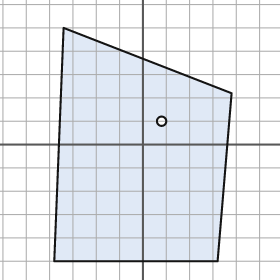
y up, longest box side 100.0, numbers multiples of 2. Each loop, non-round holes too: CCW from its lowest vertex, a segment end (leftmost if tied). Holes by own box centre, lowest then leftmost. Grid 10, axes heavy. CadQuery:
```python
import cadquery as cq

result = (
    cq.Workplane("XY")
    .moveTo(-38.0, -50.0)
    .lineTo(32.0, -50.0)
    .lineTo(38.0, 22.0)
    .lineTo(-34.0, 50.0)
    .close()
    .moveTo(8.0, 10.0)
    .circle(2.0)
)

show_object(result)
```